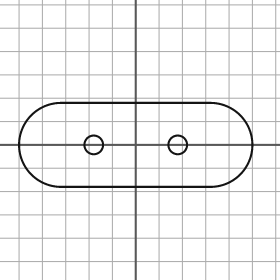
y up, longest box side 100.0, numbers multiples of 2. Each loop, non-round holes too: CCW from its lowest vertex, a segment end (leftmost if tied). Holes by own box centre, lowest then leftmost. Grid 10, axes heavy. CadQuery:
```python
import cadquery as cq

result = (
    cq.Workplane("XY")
    .moveTo(-32.0, -18.0)
    .lineTo(32.0, -18.0)
    .threePointArc((50.0, 0.0), (32.0, 18.0))
    .lineTo(-32.0, 18.0)
    .threePointArc((-50.0, 0.0), (-32.0, -18.0))
    .close()
    .moveTo(-18.0, 0.0)
    .circle(4.0)
    .moveTo(18.0, 0.0)
    .circle(4.0)
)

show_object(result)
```